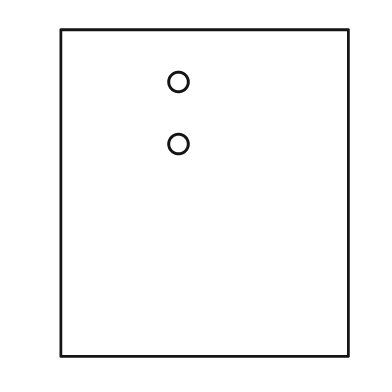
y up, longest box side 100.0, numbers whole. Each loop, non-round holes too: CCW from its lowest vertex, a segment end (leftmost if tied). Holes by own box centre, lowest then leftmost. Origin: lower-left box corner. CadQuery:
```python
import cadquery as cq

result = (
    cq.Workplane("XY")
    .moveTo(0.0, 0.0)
    .lineTo(88.0, 0.0)
    .lineTo(88.0, 100.0)
    .lineTo(0.0, 100.0)
    .close()
    .moveTo(36.0, 65.0)
    .circle(3.0)
    .moveTo(36.0, 84.0)
    .circle(3.0)
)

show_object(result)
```